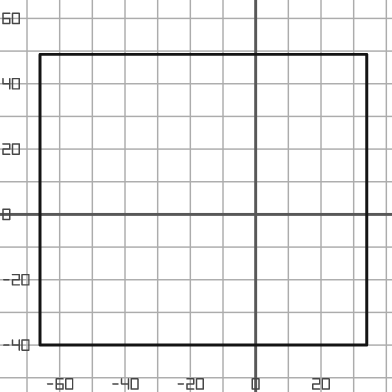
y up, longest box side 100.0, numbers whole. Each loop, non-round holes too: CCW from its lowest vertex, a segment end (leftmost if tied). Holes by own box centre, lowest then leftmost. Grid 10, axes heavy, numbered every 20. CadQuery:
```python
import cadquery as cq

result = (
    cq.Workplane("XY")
    .moveTo(-66.0, -40.0)
    .lineTo(34.0, -40.0)
    .lineTo(34.0, 49.0)
    .lineTo(-66.0, 49.0)
    .close()
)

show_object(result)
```